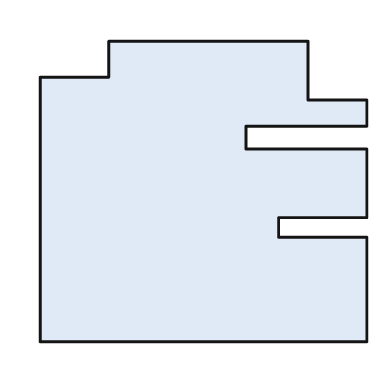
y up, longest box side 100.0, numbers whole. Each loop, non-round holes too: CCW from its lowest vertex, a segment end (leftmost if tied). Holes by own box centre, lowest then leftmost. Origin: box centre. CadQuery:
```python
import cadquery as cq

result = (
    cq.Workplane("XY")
    .moveTo(-50.0, -46.0)
    .lineTo(50.0, -46.0)
    .lineTo(50.0, -14.0)
    .lineTo(23.0, -14.0)
    .lineTo(23.0, -8.0)
    .lineTo(50.0, -8.0)
    .lineTo(50.0, 13.0)
    .lineTo(13.0, 13.0)
    .lineTo(13.0, 20.0)
    .lineTo(50.0, 20.0)
    .lineTo(50.0, 28.0)
    .lineTo(32.0, 28.0)
    .lineTo(32.0, 46.0)
    .lineTo(-29.0, 46.0)
    .lineTo(-29.0, 35.0)
    .lineTo(-50.0, 35.0)
    .close()
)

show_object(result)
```